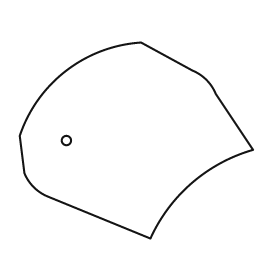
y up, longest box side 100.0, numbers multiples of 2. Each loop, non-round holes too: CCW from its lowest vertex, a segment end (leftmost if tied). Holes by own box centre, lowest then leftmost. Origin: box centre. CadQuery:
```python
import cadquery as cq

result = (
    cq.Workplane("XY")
    .moveTo(6.0, -42.0)
    .threePointArc((24.0, -18.0), (50.0, -4.0))
    .lineTo(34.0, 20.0)
    .threePointArc((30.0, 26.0), (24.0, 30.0))
    .lineTo(2.0, 42.0)
    .threePointArc((-30.0, 30.0), (-50.0, 2.0))
    .lineTo(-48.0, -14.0)
    .threePointArc((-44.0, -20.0), (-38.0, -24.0))
    .close()
    .moveTo(-30.0, 0.0)
    .circle(2.0)
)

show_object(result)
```